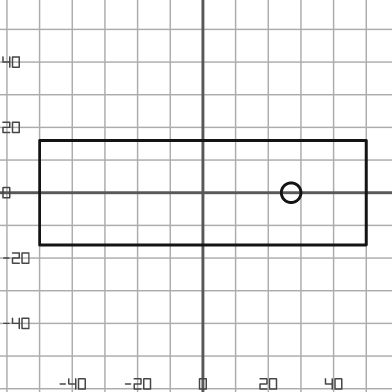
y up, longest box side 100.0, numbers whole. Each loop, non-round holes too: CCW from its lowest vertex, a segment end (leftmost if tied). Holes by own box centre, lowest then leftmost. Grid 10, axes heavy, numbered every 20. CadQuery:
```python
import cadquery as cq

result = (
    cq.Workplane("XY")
    .moveTo(-50.0, -16.0)
    .lineTo(50.0, -16.0)
    .lineTo(50.0, 16.0)
    .lineTo(-50.0, 16.0)
    .close()
    .moveTo(27.0, 0.0)
    .circle(3.0)
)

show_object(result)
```